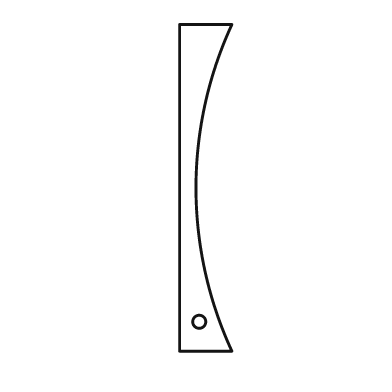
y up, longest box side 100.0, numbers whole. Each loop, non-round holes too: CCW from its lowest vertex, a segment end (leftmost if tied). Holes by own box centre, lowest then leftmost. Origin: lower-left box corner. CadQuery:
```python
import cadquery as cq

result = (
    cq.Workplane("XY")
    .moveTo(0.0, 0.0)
    .lineTo(16.0, 0.0)
    .threePointArc((5.0, 50.0), (16.0, 100.0))
    .lineTo(0.0, 100.0)
    .close()
    .moveTo(6.0, 9.0)
    .circle(2.0)
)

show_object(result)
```